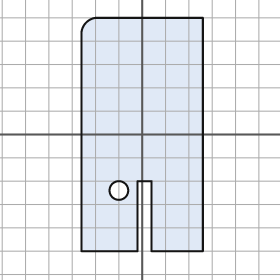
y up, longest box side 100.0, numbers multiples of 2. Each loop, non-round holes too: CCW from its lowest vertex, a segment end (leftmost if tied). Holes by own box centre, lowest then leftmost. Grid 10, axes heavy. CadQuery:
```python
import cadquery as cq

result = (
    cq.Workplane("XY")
    .moveTo(-26.0, -50.0)
    .lineTo(-2.0, -50.0)
    .lineTo(-2.0, -20.0)
    .lineTo(4.0, -20.0)
    .lineTo(4.0, -50.0)
    .lineTo(26.0, -50.0)
    .lineTo(26.0, 50.0)
    .lineTo(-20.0, 50.0)
    .threePointArc((-24.0, 48.0), (-26.0, 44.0))
    .close()
    .moveTo(-10.0, -24.0)
    .circle(4.0)
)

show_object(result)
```